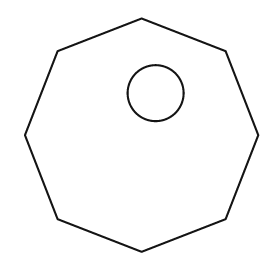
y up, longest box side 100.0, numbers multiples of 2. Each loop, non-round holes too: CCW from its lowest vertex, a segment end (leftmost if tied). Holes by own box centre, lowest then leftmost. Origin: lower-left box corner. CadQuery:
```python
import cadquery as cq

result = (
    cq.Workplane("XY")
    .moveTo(50.0, 0.0)
    .lineTo(86.0, 14.0)
    .lineTo(100.0, 50.0)
    .lineTo(86.0, 86.0)
    .lineTo(50.0, 100.0)
    .lineTo(14.0, 86.0)
    .lineTo(0.0, 50.0)
    .lineTo(14.0, 14.0)
    .close()
    .moveTo(56.0, 68.0)
    .circle(12.0)
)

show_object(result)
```